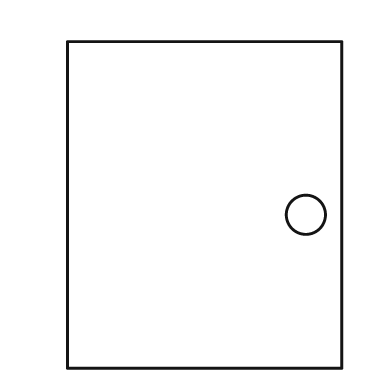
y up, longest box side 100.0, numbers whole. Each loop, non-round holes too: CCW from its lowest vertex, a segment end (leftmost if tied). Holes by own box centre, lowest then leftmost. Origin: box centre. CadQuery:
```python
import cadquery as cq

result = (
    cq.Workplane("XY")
    .moveTo(-42.0, -50.0)
    .lineTo(42.0, -50.0)
    .lineTo(42.0, 50.0)
    .lineTo(-42.0, 50.0)
    .close()
    .moveTo(31.0, -3.0)
    .circle(6.0)
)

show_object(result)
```